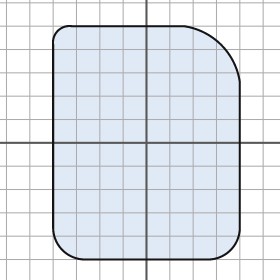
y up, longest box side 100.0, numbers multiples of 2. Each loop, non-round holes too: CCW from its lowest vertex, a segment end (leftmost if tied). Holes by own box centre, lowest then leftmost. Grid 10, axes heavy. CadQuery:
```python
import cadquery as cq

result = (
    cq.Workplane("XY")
    .moveTo(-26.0, -50.0)
    .lineTo(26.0, -50.0)
    .threePointArc((36.0, -46.0), (40.0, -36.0))
    .lineTo(40.0, 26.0)
    .threePointArc((32.0, 42.0), (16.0, 50.0))
    .lineTo(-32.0, 50.0)
    .threePointArc((-38.0, 48.0), (-40.0, 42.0))
    .lineTo(-40.0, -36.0)
    .threePointArc((-36.0, -46.0), (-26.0, -50.0))
    .close()
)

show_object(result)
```